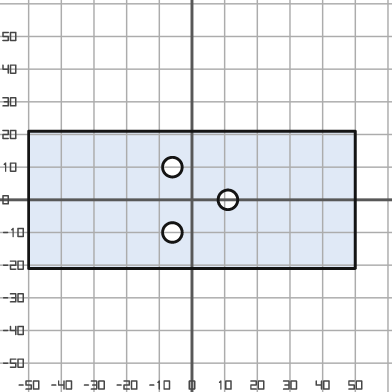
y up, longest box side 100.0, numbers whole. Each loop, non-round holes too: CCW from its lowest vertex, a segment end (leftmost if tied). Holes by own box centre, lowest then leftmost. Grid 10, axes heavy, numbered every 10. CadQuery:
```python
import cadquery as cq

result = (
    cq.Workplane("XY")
    .moveTo(-50.0, -21.0)
    .lineTo(50.0, -21.0)
    .lineTo(50.0, 21.0)
    .lineTo(-50.0, 21.0)
    .close()
    .moveTo(-6.0, -10.0)
    .circle(3.0)
    .moveTo(11.0, 0.0)
    .circle(3.0)
    .moveTo(-6.0, 10.0)
    .circle(3.0)
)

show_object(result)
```